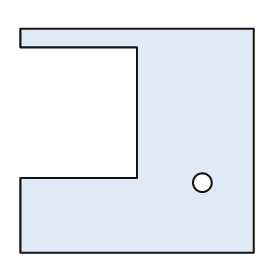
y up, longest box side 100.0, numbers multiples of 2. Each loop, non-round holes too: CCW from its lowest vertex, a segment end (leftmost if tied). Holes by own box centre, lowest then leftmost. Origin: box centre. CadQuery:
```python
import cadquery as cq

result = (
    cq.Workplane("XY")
    .moveTo(-50.0, -48.0)
    .lineTo(50.0, -48.0)
    .lineTo(50.0, 48.0)
    .lineTo(-50.0, 48.0)
    .lineTo(-50.0, 40.0)
    .lineTo(0.0, 40.0)
    .lineTo(0.0, -16.0)
    .lineTo(-50.0, -16.0)
    .close()
    .moveTo(28.0, -18.0)
    .circle(4.0)
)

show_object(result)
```